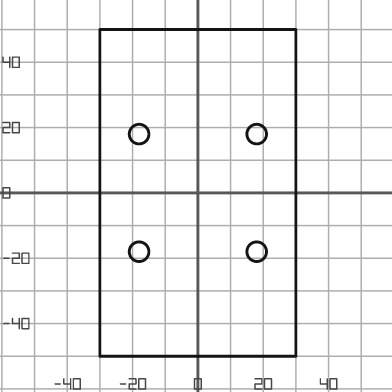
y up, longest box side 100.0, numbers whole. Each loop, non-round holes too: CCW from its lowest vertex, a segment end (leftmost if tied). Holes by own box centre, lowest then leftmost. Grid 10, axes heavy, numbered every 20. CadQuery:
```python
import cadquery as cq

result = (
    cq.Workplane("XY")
    .moveTo(-30.0, -50.0)
    .lineTo(30.0, -50.0)
    .lineTo(30.0, 50.0)
    .lineTo(-30.0, 50.0)
    .close()
    .moveTo(-18.0, -18.0)
    .circle(3.0)
    .moveTo(18.0, -18.0)
    .circle(3.0)
    .moveTo(-18.0, 18.0)
    .circle(3.0)
    .moveTo(18.0, 18.0)
    .circle(3.0)
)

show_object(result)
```